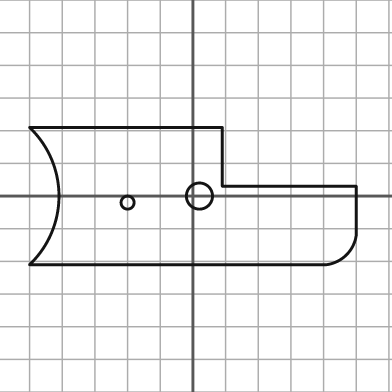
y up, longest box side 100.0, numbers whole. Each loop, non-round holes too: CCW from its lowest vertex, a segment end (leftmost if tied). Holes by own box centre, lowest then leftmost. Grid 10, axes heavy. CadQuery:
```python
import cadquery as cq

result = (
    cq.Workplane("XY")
    .moveTo(-50.0, -21.0)
    .lineTo(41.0, -21.0)
    .threePointArc((47.0, -18.0), (50.0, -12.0))
    .lineTo(50.0, 3.0)
    .lineTo(9.0, 3.0)
    .lineTo(9.0, 21.0)
    .lineTo(-50.0, 21.0)
    .threePointArc((-41.0, 0.0), (-50.0, -21.0))
    .close()
    .moveTo(-20.0, -2.0)
    .circle(2.0)
    .moveTo(2.0, 0.0)
    .circle(4.0)
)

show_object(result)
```